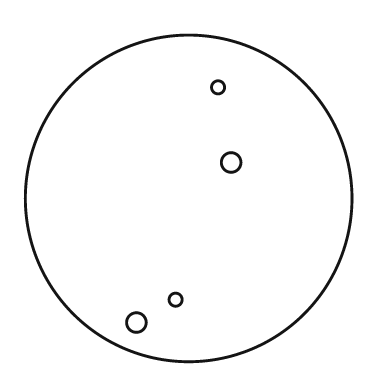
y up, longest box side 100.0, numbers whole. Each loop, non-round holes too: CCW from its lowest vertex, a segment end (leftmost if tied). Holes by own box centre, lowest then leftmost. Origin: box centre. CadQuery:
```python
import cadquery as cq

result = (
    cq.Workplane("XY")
    .moveTo(0.0, 0.0)
    .circle(50.0)
    .moveTo(-16.0, -38.0)
    .circle(3.0)
    .moveTo(-4.0, -31.0)
    .circle(2.0)
    .moveTo(13.0, 11.0)
    .circle(3.0)
    .moveTo(9.0, 34.0)
    .circle(2.0)
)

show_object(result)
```